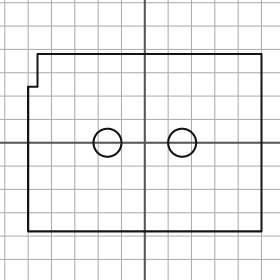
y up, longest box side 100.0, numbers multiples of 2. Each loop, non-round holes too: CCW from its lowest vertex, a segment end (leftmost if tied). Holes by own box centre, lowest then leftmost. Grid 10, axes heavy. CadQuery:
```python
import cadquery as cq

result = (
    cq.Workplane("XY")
    .moveTo(-50.0, -38.0)
    .lineTo(50.0, -38.0)
    .lineTo(50.0, 38.0)
    .lineTo(-46.0, 38.0)
    .lineTo(-46.0, 24.0)
    .lineTo(-50.0, 24.0)
    .close()
    .moveTo(-16.0, 0.0)
    .circle(6.0)
    .moveTo(16.0, 0.0)
    .circle(6.0)
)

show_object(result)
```